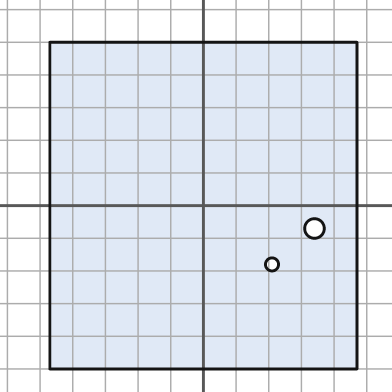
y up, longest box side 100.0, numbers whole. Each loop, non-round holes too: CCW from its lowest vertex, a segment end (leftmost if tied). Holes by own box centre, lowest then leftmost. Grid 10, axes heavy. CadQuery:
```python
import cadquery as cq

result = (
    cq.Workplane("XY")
    .moveTo(-47.0, -50.0)
    .lineTo(47.0, -50.0)
    .lineTo(47.0, 50.0)
    .lineTo(-47.0, 50.0)
    .close()
    .moveTo(21.0, -18.0)
    .circle(2.0)
    .moveTo(34.0, -7.0)
    .circle(3.0)
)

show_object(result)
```